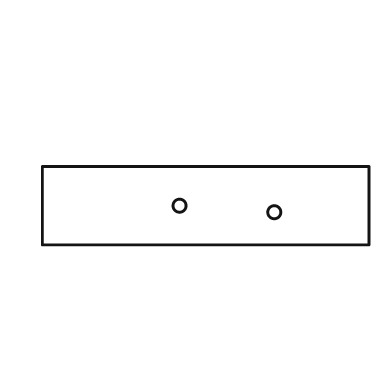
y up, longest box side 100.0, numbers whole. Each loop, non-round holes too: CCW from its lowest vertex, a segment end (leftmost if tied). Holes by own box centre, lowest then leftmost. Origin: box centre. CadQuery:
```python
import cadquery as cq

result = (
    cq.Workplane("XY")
    .moveTo(-50.0, -12.0)
    .lineTo(50.0, -12.0)
    .lineTo(50.0, 12.0)
    .lineTo(-50.0, 12.0)
    .close()
    .moveTo(21.0, -2.0)
    .circle(2.0)
    .moveTo(-8.0, 0.0)
    .circle(2.0)
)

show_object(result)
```